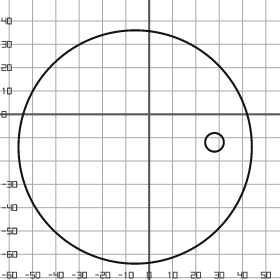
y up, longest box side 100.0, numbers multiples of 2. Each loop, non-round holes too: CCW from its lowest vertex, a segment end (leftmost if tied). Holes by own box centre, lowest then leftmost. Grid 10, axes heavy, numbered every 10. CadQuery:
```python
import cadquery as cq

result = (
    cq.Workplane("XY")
    .moveTo(-6.0, -14.0)
    .circle(50.0)
    .moveTo(28.0, -12.0)
    .circle(4.0)
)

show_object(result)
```